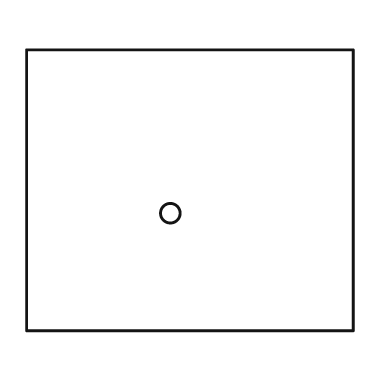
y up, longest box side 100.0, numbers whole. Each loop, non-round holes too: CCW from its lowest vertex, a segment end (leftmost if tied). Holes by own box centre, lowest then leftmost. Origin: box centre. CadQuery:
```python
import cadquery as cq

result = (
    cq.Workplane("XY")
    .moveTo(-50.0, -43.0)
    .lineTo(50.0, -43.0)
    .lineTo(50.0, 43.0)
    .lineTo(-50.0, 43.0)
    .close()
    .moveTo(-6.0, -7.0)
    .circle(3.0)
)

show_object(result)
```